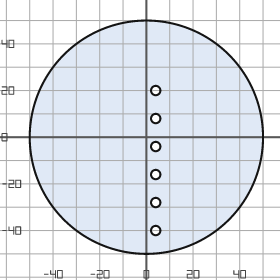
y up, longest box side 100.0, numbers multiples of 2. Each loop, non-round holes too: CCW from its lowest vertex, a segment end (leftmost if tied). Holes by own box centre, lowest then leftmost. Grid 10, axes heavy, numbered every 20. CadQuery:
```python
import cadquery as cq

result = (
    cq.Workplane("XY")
    .moveTo(0.0, 0.0)
    .circle(50.0)
    .moveTo(4.0, -40.0)
    .circle(2.0)
    .moveTo(4.0, -28.0)
    .circle(2.0)
    .moveTo(4.0, -16.0)
    .circle(2.0)
    .moveTo(4.0, -4.0)
    .circle(2.0)
    .moveTo(4.0, 8.0)
    .circle(2.0)
    .moveTo(4.0, 20.0)
    .circle(2.0)
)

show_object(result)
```